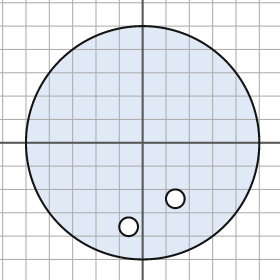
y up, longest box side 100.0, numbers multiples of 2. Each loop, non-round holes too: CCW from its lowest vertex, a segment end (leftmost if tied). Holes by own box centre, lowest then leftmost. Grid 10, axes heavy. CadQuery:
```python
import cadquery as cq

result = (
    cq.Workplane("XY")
    .moveTo(0.0, 0.0)
    .circle(50.0)
    .moveTo(-6.0, -36.0)
    .circle(4.0)
    .moveTo(14.0, -24.0)
    .circle(4.0)
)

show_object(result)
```